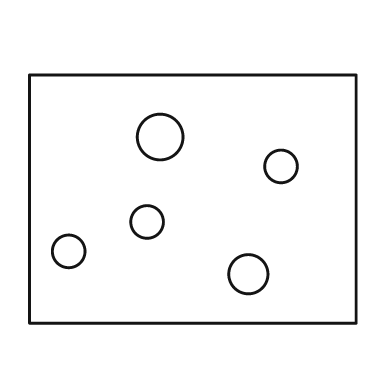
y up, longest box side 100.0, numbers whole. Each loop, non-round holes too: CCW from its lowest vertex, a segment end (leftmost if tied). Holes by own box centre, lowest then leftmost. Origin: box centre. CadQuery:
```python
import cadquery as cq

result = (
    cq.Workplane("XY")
    .moveTo(-50.0, -38.0)
    .lineTo(50.0, -38.0)
    .lineTo(50.0, 38.0)
    .lineTo(-50.0, 38.0)
    .close()
    .moveTo(17.0, -23.0)
    .circle(6.0)
    .moveTo(-38.0, -16.0)
    .circle(5.0)
    .moveTo(-14.0, -7.0)
    .circle(5.0)
    .moveTo(27.0, 10.0)
    .circle(5.0)
    .moveTo(-10.0, 19.0)
    .circle(7.0)
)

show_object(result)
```